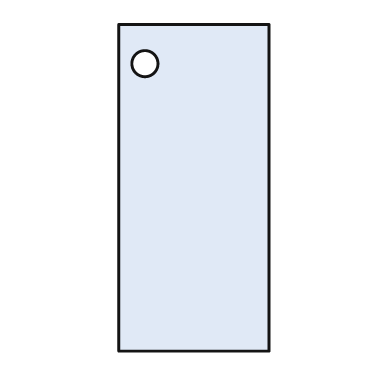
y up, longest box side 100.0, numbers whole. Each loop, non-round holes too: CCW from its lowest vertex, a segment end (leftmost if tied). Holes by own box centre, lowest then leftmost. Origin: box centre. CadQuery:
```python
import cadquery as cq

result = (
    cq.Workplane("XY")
    .moveTo(-23.0, -50.0)
    .lineTo(23.0, -50.0)
    .lineTo(23.0, 50.0)
    .lineTo(-23.0, 50.0)
    .close()
    .moveTo(-15.0, 38.0)
    .circle(4.0)
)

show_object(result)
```